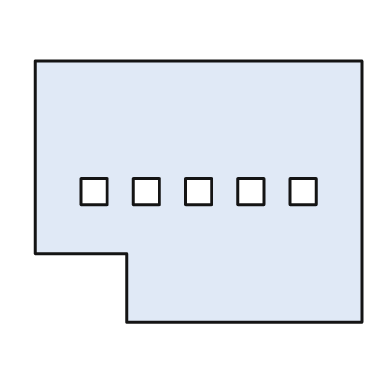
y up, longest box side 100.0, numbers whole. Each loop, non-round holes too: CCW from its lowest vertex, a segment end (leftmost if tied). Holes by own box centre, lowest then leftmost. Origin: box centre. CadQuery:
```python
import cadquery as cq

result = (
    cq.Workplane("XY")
    .moveTo(-22.0, -40.0)
    .lineTo(50.0, -40.0)
    .lineTo(50.0, 40.0)
    .lineTo(-50.0, 40.0)
    .lineTo(-50.0, -19.0)
    .lineTo(-22.0, -19.0)
    .close()
    .moveTo(-36.0, -4.0)
    .lineTo(-28.0, -4.0)
    .lineTo(-28.0, 4.0)
    .lineTo(-36.0, 4.0)
    .close()
    .moveTo(-20.0, -4.0)
    .lineTo(-12.0, -4.0)
    .lineTo(-12.0, 4.0)
    .lineTo(-20.0, 4.0)
    .close()
    .moveTo(-4.0, -4.0)
    .lineTo(4.0, -4.0)
    .lineTo(4.0, 4.0)
    .lineTo(-4.0, 4.0)
    .close()
    .moveTo(12.0, -4.0)
    .lineTo(20.0, -4.0)
    .lineTo(20.0, 4.0)
    .lineTo(12.0, 4.0)
    .close()
    .moveTo(28.0, -4.0)
    .lineTo(36.0, -4.0)
    .lineTo(36.0, 4.0)
    .lineTo(28.0, 4.0)
    .close()
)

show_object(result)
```